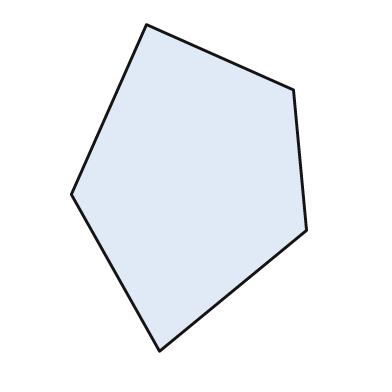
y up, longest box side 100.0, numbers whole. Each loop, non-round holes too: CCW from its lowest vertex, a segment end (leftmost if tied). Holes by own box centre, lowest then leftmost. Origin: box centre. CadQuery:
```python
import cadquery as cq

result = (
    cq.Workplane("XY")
    .moveTo(-9.0, -50.0)
    .lineTo(36.0, -13.0)
    .lineTo(32.0, 30.0)
    .lineTo(-13.0, 50.0)
    .lineTo(-36.0, -2.0)
    .close()
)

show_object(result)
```